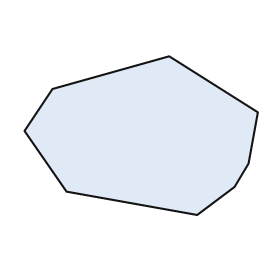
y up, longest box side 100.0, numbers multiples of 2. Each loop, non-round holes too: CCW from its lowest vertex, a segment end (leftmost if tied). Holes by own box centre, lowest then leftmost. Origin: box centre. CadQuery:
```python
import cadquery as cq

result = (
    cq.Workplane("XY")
    .moveTo(24.0, -34.0)
    .lineTo(40.0, -22.0)
    .lineTo(46.0, -12.0)
    .lineTo(50.0, 10.0)
    .lineTo(12.0, 34.0)
    .lineTo(-38.0, 20.0)
    .lineTo(-50.0, 2.0)
    .lineTo(-32.0, -24.0)
    .close()
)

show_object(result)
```